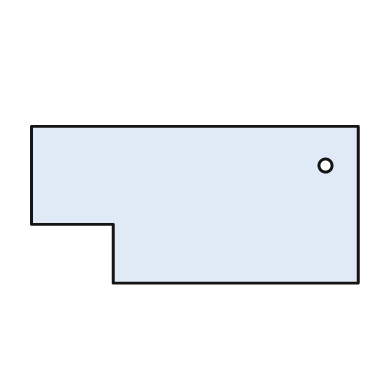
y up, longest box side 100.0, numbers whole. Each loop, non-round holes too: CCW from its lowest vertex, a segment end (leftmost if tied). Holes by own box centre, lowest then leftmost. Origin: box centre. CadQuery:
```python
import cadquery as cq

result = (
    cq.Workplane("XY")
    .moveTo(-25.0, -24.0)
    .lineTo(50.0, -24.0)
    .lineTo(50.0, 24.0)
    .lineTo(-50.0, 24.0)
    .lineTo(-50.0, -6.0)
    .lineTo(-25.0, -6.0)
    .close()
    .moveTo(40.0, 12.0)
    .circle(2.0)
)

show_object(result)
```